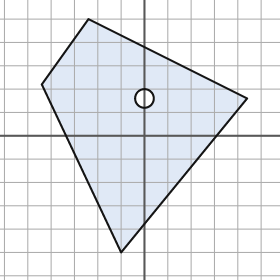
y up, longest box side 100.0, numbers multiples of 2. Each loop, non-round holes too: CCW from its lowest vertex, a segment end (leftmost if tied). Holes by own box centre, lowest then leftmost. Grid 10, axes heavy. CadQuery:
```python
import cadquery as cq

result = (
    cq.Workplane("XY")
    .moveTo(-10.0, -50.0)
    .lineTo(44.0, 16.0)
    .lineTo(-24.0, 50.0)
    .lineTo(-44.0, 22.0)
    .close()
    .moveTo(0.0, 16.0)
    .circle(4.0)
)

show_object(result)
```